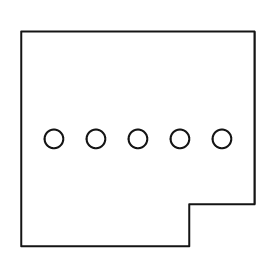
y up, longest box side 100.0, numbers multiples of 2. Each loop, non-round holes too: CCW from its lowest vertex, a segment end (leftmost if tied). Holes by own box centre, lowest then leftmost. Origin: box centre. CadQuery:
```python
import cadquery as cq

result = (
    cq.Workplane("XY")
    .moveTo(-50.0, -46.0)
    .lineTo(22.0, -46.0)
    .lineTo(22.0, -28.0)
    .lineTo(50.0, -28.0)
    .lineTo(50.0, 46.0)
    .lineTo(-50.0, 46.0)
    .close()
    .moveTo(-36.0, 0.0)
    .circle(4.0)
    .moveTo(-18.0, 0.0)
    .circle(4.0)
    .moveTo(0.0, 0.0)
    .circle(4.0)
    .moveTo(18.0, 0.0)
    .circle(4.0)
    .moveTo(36.0, 0.0)
    .circle(4.0)
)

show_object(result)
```